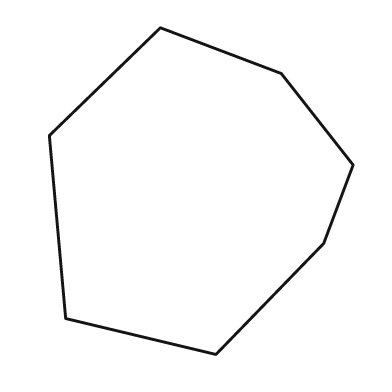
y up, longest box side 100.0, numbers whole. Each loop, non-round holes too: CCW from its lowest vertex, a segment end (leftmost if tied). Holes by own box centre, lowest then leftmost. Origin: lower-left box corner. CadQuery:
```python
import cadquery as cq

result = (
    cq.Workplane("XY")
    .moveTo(51.0, 0.0)
    .lineTo(84.0, 34.0)
    .lineTo(93.0, 58.0)
    .lineTo(71.0, 86.0)
    .lineTo(34.0, 100.0)
    .lineTo(0.0, 67.0)
    .lineTo(5.0, 11.0)
    .close()
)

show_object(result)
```